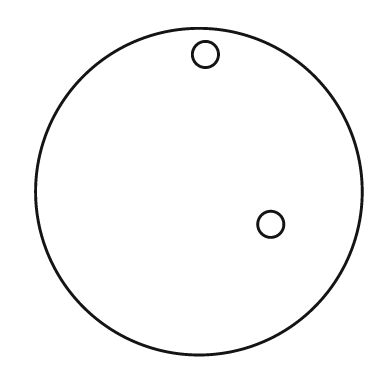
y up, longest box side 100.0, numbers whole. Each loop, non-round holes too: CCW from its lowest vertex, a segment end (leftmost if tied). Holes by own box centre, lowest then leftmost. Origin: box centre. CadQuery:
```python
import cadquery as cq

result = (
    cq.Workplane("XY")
    .moveTo(0.0, 0.0)
    .circle(50.0)
    .moveTo(22.0, -10.0)
    .circle(4.0)
    .moveTo(2.0, 42.0)
    .circle(4.0)
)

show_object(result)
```